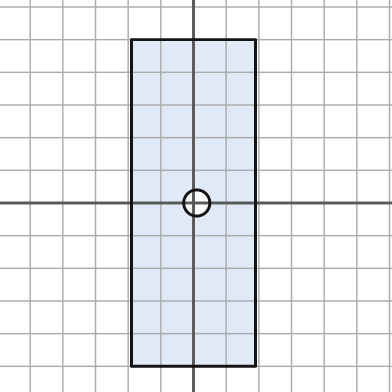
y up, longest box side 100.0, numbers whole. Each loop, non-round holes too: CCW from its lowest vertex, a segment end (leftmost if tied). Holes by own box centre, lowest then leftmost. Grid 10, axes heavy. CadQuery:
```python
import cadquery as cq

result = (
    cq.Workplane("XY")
    .moveTo(-19.0, -50.0)
    .lineTo(19.0, -50.0)
    .lineTo(19.0, 50.0)
    .lineTo(-19.0, 50.0)
    .close()
    .moveTo(1.0, 0.0)
    .circle(4.0)
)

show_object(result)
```